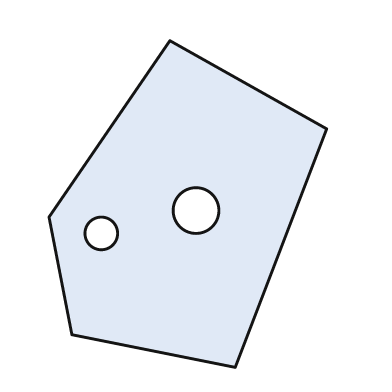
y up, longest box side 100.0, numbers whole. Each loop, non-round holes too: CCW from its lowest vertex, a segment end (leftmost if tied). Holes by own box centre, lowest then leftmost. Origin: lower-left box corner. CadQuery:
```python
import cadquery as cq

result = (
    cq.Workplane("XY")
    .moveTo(57.0, 0.0)
    .lineTo(85.0, 73.0)
    .lineTo(37.0, 100.0)
    .lineTo(0.0, 46.0)
    .lineTo(7.0, 10.0)
    .close()
    .moveTo(16.0, 41.0)
    .circle(5.0)
    .moveTo(45.0, 48.0)
    .circle(7.0)
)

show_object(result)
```